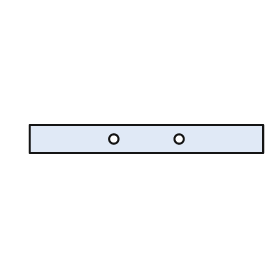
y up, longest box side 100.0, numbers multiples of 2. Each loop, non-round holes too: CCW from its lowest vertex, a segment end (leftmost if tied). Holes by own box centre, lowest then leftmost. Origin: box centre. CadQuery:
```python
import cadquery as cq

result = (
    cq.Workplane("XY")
    .moveTo(-50.0, -6.0)
    .lineTo(50.0, -6.0)
    .lineTo(50.0, 6.0)
    .lineTo(-50.0, 6.0)
    .close()
    .moveTo(-14.0, 0.0)
    .circle(2.0)
    .moveTo(14.0, 0.0)
    .circle(2.0)
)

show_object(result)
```